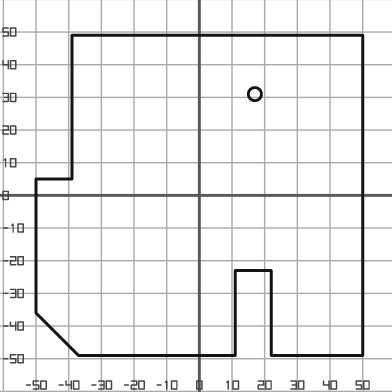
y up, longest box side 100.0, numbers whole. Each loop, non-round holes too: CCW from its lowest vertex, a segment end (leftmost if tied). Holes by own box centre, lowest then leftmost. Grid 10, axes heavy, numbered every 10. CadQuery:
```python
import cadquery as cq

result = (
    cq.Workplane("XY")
    .moveTo(-37.0, -49.0)
    .lineTo(11.0, -49.0)
    .lineTo(11.0, -23.0)
    .lineTo(22.0, -23.0)
    .lineTo(22.0, -49.0)
    .lineTo(50.0, -49.0)
    .lineTo(50.0, 49.0)
    .lineTo(-39.0, 49.0)
    .lineTo(-39.0, 5.0)
    .lineTo(-50.0, 5.0)
    .lineTo(-50.0, -36.0)
    .close()
    .moveTo(17.0, 31.0)
    .circle(2.0)
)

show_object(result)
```